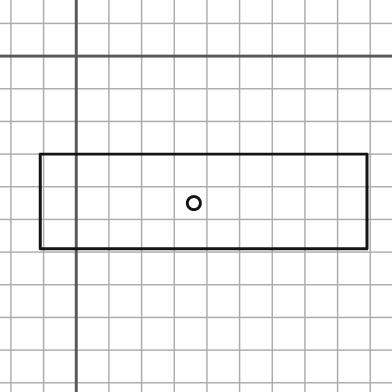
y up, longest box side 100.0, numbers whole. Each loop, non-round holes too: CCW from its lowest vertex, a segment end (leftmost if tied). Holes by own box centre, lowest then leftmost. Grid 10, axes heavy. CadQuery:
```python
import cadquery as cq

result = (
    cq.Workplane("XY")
    .moveTo(-11.0, -59.0)
    .lineTo(89.0, -59.0)
    .lineTo(89.0, -30.0)
    .lineTo(-11.0, -30.0)
    .close()
    .moveTo(36.0, -45.0)
    .circle(2.0)
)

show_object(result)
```